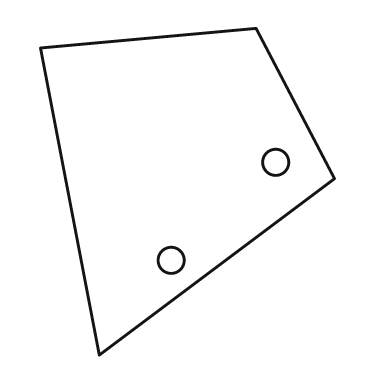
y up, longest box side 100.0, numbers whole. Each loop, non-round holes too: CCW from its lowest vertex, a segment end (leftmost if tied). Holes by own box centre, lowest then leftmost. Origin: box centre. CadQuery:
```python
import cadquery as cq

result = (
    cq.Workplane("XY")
    .moveTo(-27.0, -50.0)
    .lineTo(45.0, 4.0)
    .lineTo(21.0, 50.0)
    .lineTo(-45.0, 44.0)
    .close()
    .moveTo(-5.0, -21.0)
    .circle(4.0)
    .moveTo(27.0, 9.0)
    .circle(4.0)
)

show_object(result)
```